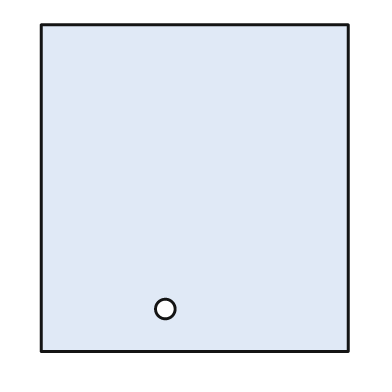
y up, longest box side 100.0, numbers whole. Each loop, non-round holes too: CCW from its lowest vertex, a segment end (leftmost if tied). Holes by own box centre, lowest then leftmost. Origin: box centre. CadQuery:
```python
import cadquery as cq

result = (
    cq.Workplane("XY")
    .moveTo(-47.0, -50.0)
    .lineTo(47.0, -50.0)
    .lineTo(47.0, 50.0)
    .lineTo(-47.0, 50.0)
    .close()
    .moveTo(-9.0, -37.0)
    .circle(3.0)
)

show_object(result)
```